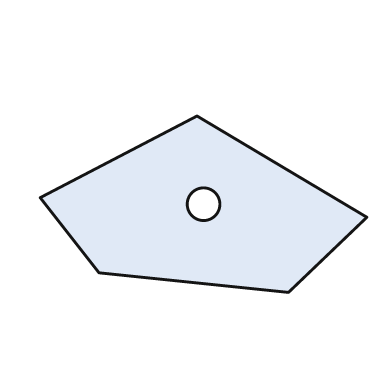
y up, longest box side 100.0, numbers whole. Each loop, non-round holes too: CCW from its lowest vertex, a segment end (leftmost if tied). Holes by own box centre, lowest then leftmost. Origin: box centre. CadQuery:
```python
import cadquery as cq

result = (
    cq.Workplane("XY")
    .moveTo(26.0, -27.0)
    .lineTo(50.0, -4.0)
    .lineTo(-2.0, 27.0)
    .lineTo(-50.0, 2.0)
    .lineTo(-32.0, -21.0)
    .close()
    .moveTo(0.0, 0.0)
    .circle(5.0)
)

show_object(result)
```